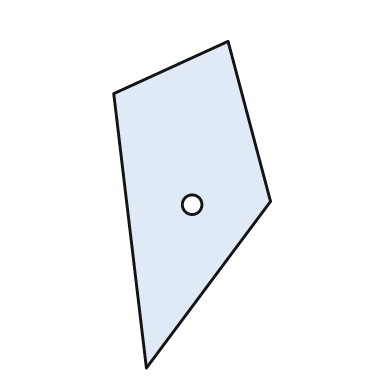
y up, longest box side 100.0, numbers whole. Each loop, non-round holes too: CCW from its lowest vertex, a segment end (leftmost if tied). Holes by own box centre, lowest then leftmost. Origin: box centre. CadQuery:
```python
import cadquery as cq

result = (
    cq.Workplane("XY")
    .moveTo(-14.0, -50.0)
    .lineTo(24.0, 1.0)
    .lineTo(11.0, 50.0)
    .lineTo(-24.0, 34.0)
    .close()
    .moveTo(0.0, 0.0)
    .circle(3.0)
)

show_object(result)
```